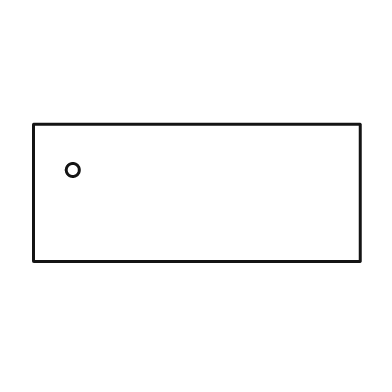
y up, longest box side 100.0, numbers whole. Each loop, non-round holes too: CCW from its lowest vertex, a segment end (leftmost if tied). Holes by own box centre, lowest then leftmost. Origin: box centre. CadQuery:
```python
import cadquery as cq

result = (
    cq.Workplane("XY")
    .moveTo(-50.0, -21.0)
    .lineTo(50.0, -21.0)
    .lineTo(50.0, 21.0)
    .lineTo(-50.0, 21.0)
    .close()
    .moveTo(-38.0, 7.0)
    .circle(2.0)
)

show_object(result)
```